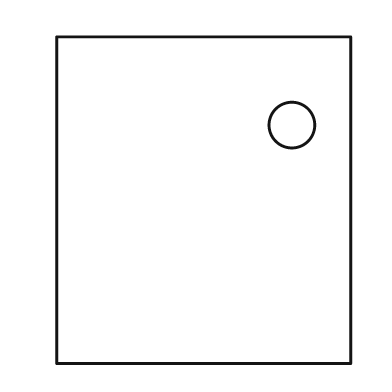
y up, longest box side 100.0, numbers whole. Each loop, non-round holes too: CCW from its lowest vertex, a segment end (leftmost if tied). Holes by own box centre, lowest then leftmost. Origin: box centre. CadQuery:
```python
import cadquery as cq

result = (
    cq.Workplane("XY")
    .moveTo(-45.0, -50.0)
    .lineTo(45.0, -50.0)
    .lineTo(45.0, 50.0)
    .lineTo(-45.0, 50.0)
    .close()
    .moveTo(27.0, 23.0)
    .circle(7.0)
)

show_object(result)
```